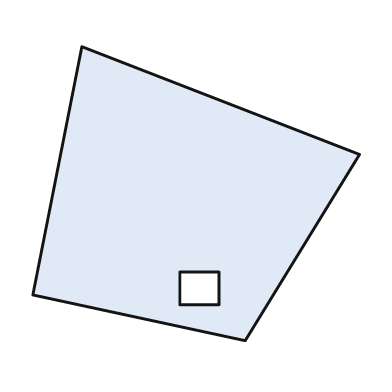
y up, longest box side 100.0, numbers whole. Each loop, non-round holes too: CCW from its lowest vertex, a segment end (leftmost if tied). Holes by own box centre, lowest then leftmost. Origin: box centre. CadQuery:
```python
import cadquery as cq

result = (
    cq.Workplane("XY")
    .moveTo(15.0, -45.0)
    .lineTo(50.0, 12.0)
    .lineTo(-35.0, 45.0)
    .lineTo(-50.0, -31.0)
    .close()
    .moveTo(-5.0, -34.0)
    .lineTo(7.0, -34.0)
    .lineTo(7.0, -24.0)
    .lineTo(-5.0, -24.0)
    .close()
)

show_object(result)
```